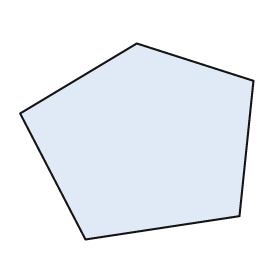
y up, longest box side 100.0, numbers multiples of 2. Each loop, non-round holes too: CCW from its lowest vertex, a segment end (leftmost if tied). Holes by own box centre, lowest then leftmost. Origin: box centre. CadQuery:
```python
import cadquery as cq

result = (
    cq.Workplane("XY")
    .moveTo(-22.0, -42.0)
    .lineTo(44.0, -32.0)
    .lineTo(50.0, 26.0)
    .lineTo(0.0, 42.0)
    .lineTo(-50.0, 12.0)
    .close()
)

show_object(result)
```